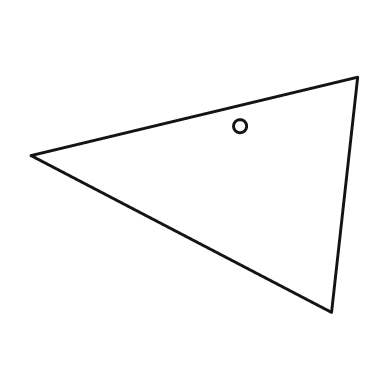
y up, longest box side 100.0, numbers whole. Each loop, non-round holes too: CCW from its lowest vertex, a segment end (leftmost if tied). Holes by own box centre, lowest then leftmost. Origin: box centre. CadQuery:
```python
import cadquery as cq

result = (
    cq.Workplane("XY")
    .moveTo(42.0, -36.0)
    .lineTo(50.0, 36.0)
    .lineTo(-50.0, 12.0)
    .close()
    .moveTo(14.0, 21.0)
    .circle(2.0)
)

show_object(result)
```